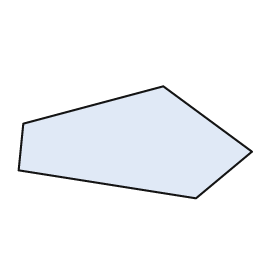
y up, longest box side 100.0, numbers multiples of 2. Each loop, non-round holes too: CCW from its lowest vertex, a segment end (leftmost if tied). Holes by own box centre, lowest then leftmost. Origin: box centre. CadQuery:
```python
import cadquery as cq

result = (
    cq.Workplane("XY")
    .moveTo(26.0, -24.0)
    .lineTo(50.0, -4.0)
    .lineTo(12.0, 24.0)
    .lineTo(-48.0, 8.0)
    .lineTo(-50.0, -12.0)
    .close()
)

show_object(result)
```